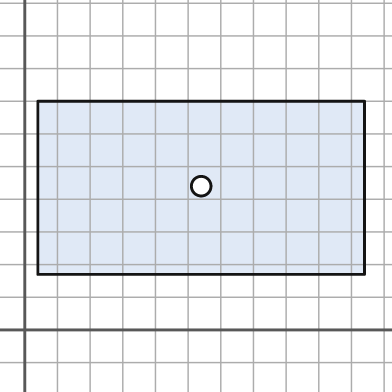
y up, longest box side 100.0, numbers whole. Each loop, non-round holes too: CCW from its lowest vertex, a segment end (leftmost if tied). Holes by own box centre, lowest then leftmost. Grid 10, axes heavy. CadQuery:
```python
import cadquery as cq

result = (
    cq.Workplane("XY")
    .moveTo(4.0, 17.0)
    .lineTo(104.0, 17.0)
    .lineTo(104.0, 70.0)
    .lineTo(4.0, 70.0)
    .close()
    .moveTo(54.0, 44.0)
    .circle(3.0)
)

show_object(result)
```